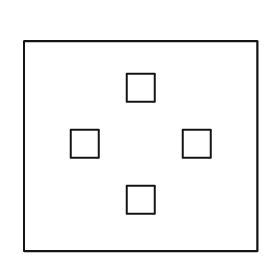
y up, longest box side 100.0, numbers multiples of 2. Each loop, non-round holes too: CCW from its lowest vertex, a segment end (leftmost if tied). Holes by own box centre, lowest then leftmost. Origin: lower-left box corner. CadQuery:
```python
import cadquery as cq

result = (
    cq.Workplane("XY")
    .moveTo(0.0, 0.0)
    .lineTo(100.0, 0.0)
    .lineTo(100.0, 90.0)
    .lineTo(0.0, 90.0)
    .close()
    .moveTo(44.0, 16.0)
    .lineTo(56.0, 16.0)
    .lineTo(56.0, 28.0)
    .lineTo(44.0, 28.0)
    .close()
    .moveTo(20.0, 40.0)
    .lineTo(32.0, 40.0)
    .lineTo(32.0, 52.0)
    .lineTo(20.0, 52.0)
    .close()
    .moveTo(68.0, 40.0)
    .lineTo(80.0, 40.0)
    .lineTo(80.0, 52.0)
    .lineTo(68.0, 52.0)
    .close()
    .moveTo(44.0, 64.0)
    .lineTo(56.0, 64.0)
    .lineTo(56.0, 76.0)
    .lineTo(44.0, 76.0)
    .close()
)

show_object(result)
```